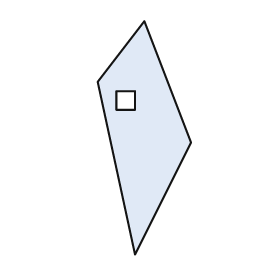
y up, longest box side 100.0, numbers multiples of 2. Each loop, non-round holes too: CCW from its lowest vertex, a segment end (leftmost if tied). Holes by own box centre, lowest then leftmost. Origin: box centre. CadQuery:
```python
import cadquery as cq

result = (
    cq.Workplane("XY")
    .moveTo(-4.0, -50.0)
    .lineTo(20.0, -2.0)
    .lineTo(0.0, 50.0)
    .lineTo(-20.0, 24.0)
    .close()
    .moveTo(-12.0, 12.0)
    .lineTo(-4.0, 12.0)
    .lineTo(-4.0, 20.0)
    .lineTo(-12.0, 20.0)
    .close()
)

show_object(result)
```